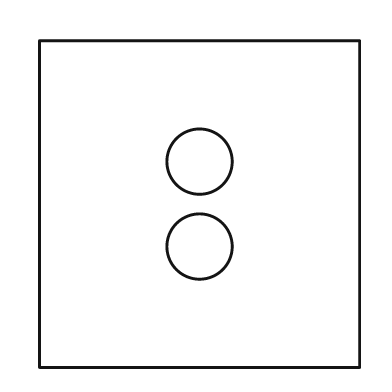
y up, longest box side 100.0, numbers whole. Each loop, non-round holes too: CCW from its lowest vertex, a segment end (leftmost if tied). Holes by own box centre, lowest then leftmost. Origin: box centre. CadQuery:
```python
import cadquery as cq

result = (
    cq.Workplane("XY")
    .moveTo(-49.0, -50.0)
    .lineTo(49.0, -50.0)
    .lineTo(49.0, 50.0)
    .lineTo(-49.0, 50.0)
    .close()
    .moveTo(0.0, -13.0)
    .circle(10.0)
    .moveTo(0.0, 13.0)
    .circle(10.0)
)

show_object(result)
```